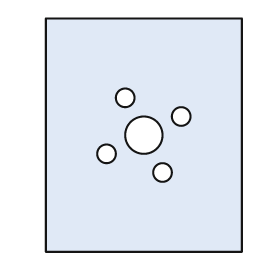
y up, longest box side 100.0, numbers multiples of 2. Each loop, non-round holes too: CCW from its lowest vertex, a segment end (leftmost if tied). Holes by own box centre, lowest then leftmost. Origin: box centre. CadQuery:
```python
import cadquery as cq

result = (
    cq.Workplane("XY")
    .moveTo(-42.0, -50.0)
    .lineTo(42.0, -50.0)
    .lineTo(42.0, 50.0)
    .lineTo(-42.0, 50.0)
    .close()
    .moveTo(8.0, -16.0)
    .circle(4.0)
    .moveTo(-16.0, -8.0)
    .circle(4.0)
    .moveTo(0.0, 0.0)
    .circle(8.0)
    .moveTo(16.0, 8.0)
    .circle(4.0)
    .moveTo(-8.0, 16.0)
    .circle(4.0)
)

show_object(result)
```